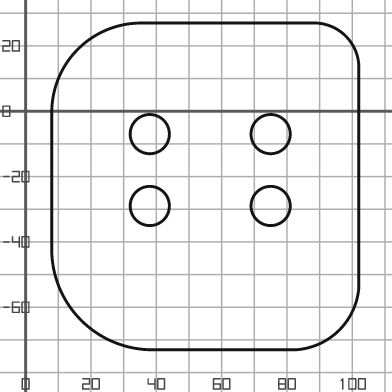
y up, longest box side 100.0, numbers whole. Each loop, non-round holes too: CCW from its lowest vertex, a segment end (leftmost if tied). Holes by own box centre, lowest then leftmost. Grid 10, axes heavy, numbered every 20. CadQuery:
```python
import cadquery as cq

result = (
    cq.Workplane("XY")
    .moveTo(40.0, -73.0)
    .lineTo(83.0, -73.0)
    .threePointArc((96.0, -67.0), (102.0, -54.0))
    .lineTo(102.0, 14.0)
    .threePointArc((98.0, 23.0), (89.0, 27.0))
    .lineTo(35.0, 27.0)
    .threePointArc((16.0, 19.0), (8.0, 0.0))
    .lineTo(8.0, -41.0)
    .threePointArc((17.0, -64.0), (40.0, -73.0))
    .close()
    .moveTo(38.0, -29.0)
    .circle(6.0)
    .moveTo(75.0, -29.0)
    .circle(6.0)
    .moveTo(38.0, -7.0)
    .circle(6.0)
    .moveTo(75.0, -7.0)
    .circle(6.0)
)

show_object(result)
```